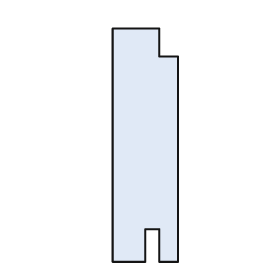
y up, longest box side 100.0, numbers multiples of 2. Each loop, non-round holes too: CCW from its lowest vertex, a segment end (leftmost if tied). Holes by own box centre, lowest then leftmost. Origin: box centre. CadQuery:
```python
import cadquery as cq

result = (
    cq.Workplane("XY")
    .moveTo(-14.0, -50.0)
    .lineTo(0.0, -50.0)
    .lineTo(0.0, -36.0)
    .lineTo(6.0, -36.0)
    .lineTo(6.0, -50.0)
    .lineTo(14.0, -50.0)
    .lineTo(14.0, 38.0)
    .lineTo(6.0, 38.0)
    .lineTo(6.0, 50.0)
    .lineTo(-14.0, 50.0)
    .close()
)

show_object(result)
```